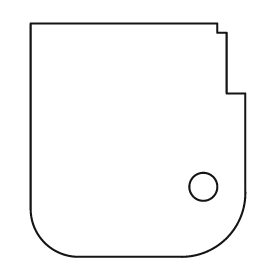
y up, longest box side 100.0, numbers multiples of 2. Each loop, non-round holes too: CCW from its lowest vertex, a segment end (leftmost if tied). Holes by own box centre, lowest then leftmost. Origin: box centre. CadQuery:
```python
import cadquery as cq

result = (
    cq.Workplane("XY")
    .moveTo(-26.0, -50.0)
    .lineTo(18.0, -50.0)
    .threePointArc((38.0, -42.0), (46.0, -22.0))
    .lineTo(46.0, 20.0)
    .lineTo(38.0, 20.0)
    .lineTo(38.0, 46.0)
    .lineTo(34.0, 46.0)
    .lineTo(34.0, 50.0)
    .lineTo(-46.0, 50.0)
    .lineTo(-46.0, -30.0)
    .threePointArc((-40.0, -44.0), (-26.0, -50.0))
    .close()
    .moveTo(28.0, -20.0)
    .circle(6.0)
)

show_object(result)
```